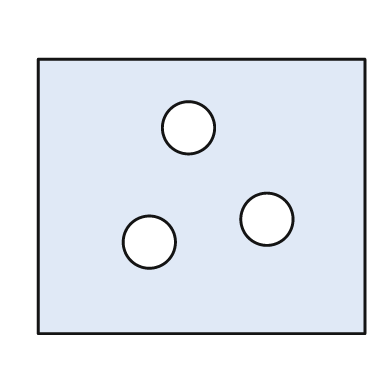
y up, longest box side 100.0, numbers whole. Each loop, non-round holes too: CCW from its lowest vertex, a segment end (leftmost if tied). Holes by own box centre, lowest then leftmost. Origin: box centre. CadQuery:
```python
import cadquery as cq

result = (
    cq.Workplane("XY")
    .moveTo(-50.0, -42.0)
    .lineTo(50.0, -42.0)
    .lineTo(50.0, 42.0)
    .lineTo(-50.0, 42.0)
    .close()
    .moveTo(-16.0, -14.0)
    .circle(8.0)
    .moveTo(20.0, -7.0)
    .circle(8.0)
    .moveTo(-4.0, 21.0)
    .circle(8.0)
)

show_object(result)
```